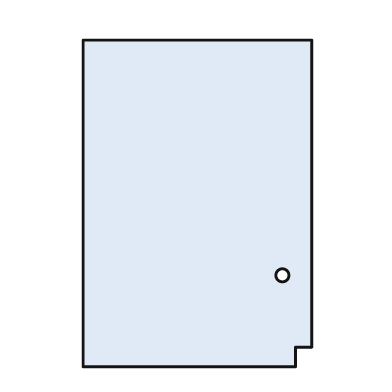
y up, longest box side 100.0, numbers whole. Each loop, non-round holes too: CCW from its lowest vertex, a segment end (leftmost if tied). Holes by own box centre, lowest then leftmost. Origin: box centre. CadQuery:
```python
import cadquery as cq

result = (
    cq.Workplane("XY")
    .moveTo(-35.0, -50.0)
    .lineTo(30.0, -50.0)
    .lineTo(30.0, -44.0)
    .lineTo(35.0, -44.0)
    .lineTo(35.0, 50.0)
    .lineTo(-35.0, 50.0)
    .close()
    .moveTo(26.0, -22.0)
    .circle(2.0)
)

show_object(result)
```